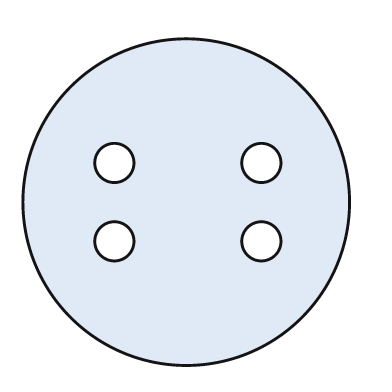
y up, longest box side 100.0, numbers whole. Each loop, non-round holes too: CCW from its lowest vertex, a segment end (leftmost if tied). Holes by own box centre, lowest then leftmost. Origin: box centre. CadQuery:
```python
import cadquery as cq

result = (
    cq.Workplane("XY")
    .moveTo(0.0, 0.0)
    .circle(50.0)
    .moveTo(-22.0, -12.0)
    .circle(6.0)
    .moveTo(23.0, -12.0)
    .circle(6.0)
    .moveTo(-22.0, 12.0)
    .circle(6.0)
    .moveTo(23.0, 12.0)
    .circle(6.0)
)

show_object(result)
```